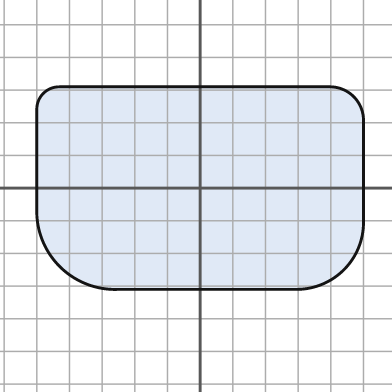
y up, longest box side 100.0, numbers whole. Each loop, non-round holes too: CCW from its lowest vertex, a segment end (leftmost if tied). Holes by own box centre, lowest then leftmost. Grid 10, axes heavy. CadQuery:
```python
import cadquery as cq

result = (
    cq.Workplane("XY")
    .moveTo(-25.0, -31.0)
    .lineTo(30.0, -31.0)
    .threePointArc((44.0, -25.0), (50.0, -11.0))
    .lineTo(50.0, 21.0)
    .threePointArc((47.0, 28.0), (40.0, 31.0))
    .lineTo(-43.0, 31.0)
    .threePointArc((-48.0, 29.0), (-50.0, 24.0))
    .lineTo(-50.0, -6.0)
    .threePointArc((-43.0, -24.0), (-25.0, -31.0))
    .close()
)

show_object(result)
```